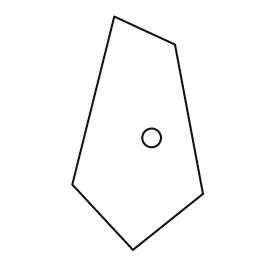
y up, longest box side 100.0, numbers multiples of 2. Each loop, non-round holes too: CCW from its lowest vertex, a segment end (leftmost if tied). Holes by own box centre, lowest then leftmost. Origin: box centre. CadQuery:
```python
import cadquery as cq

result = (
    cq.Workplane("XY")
    .moveTo(-2.0, -50.0)
    .lineTo(28.0, -26.0)
    .lineTo(16.0, 38.0)
    .lineTo(-10.0, 50.0)
    .lineTo(-28.0, -22.0)
    .close()
    .moveTo(6.0, -2.0)
    .circle(4.0)
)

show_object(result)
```